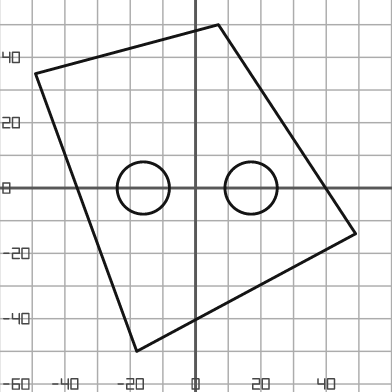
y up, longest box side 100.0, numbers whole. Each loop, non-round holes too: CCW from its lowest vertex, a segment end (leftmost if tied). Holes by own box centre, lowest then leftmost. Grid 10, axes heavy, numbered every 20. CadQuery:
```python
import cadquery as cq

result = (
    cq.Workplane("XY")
    .moveTo(-18.0, -50.0)
    .lineTo(49.0, -14.0)
    .lineTo(7.0, 50.0)
    .lineTo(-49.0, 35.0)
    .close()
    .moveTo(-16.0, 0.0)
    .circle(8.0)
    .moveTo(17.0, 0.0)
    .circle(8.0)
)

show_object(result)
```